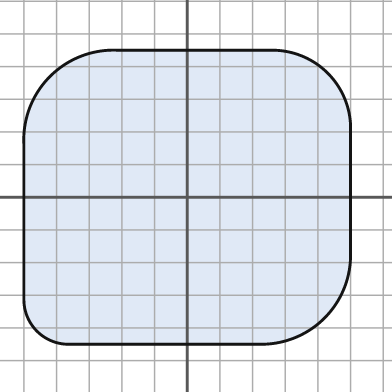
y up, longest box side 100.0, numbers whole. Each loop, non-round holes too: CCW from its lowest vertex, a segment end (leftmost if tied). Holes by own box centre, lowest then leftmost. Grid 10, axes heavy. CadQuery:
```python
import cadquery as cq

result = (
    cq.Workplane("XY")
    .moveTo(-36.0, -45.0)
    .lineTo(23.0, -45.0)
    .threePointArc((42.0, -37.0), (50.0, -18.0))
    .lineTo(50.0, 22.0)
    .threePointArc((43.0, 38.0), (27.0, 45.0))
    .lineTo(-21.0, 45.0)
    .threePointArc((-42.0, 37.0), (-50.0, 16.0))
    .lineTo(-50.0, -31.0)
    .threePointArc((-46.0, -41.0), (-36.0, -45.0))
    .close()
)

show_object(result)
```